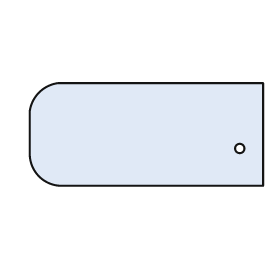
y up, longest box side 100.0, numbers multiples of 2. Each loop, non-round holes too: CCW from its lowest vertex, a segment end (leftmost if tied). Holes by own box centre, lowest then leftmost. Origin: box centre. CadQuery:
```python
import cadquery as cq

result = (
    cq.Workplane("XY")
    .moveTo(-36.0, -22.0)
    .lineTo(50.0, -22.0)
    .lineTo(50.0, 22.0)
    .lineTo(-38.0, 22.0)
    .threePointArc((-46.0, 18.0), (-50.0, 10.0))
    .lineTo(-50.0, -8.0)
    .threePointArc((-46.0, -18.0), (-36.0, -22.0))
    .close()
    .moveTo(40.0, -6.0)
    .circle(2.0)
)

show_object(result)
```